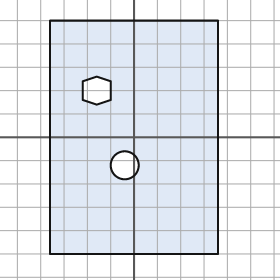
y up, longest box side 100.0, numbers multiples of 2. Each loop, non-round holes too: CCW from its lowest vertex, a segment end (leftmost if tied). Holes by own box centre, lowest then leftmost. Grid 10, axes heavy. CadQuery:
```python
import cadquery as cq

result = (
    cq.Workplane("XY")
    .moveTo(-36.0, -50.0)
    .lineTo(36.0, -50.0)
    .lineTo(36.0, 50.0)
    .lineTo(-36.0, 50.0)
    .close()
    .moveTo(-4.0, -12.0)
    .circle(6.0)
    .moveTo(-16.0, 14.0)
    .lineTo(-10.0, 16.0)
    .lineTo(-10.0, 24.0)
    .lineTo(-16.0, 26.0)
    .lineTo(-22.0, 24.0)
    .lineTo(-22.0, 16.0)
    .close()
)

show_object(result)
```